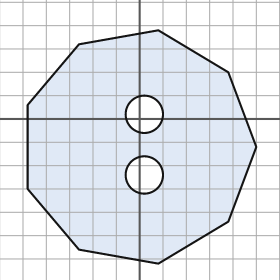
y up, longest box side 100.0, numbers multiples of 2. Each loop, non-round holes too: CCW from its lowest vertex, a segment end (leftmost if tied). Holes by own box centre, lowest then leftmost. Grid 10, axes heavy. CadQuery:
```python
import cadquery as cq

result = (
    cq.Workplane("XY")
    .moveTo(8.0, -62.0)
    .lineTo(38.0, -44.0)
    .lineTo(50.0, -12.0)
    .lineTo(38.0, 20.0)
    .lineTo(8.0, 38.0)
    .lineTo(-26.0, 32.0)
    .lineTo(-48.0, 6.0)
    .lineTo(-48.0, -30.0)
    .lineTo(-26.0, -56.0)
    .close()
    .moveTo(2.0, -24.0)
    .circle(8.0)
    .moveTo(2.0, 2.0)
    .circle(8.0)
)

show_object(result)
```